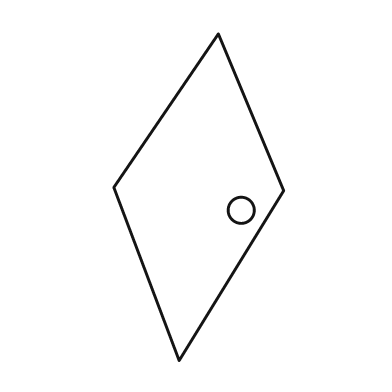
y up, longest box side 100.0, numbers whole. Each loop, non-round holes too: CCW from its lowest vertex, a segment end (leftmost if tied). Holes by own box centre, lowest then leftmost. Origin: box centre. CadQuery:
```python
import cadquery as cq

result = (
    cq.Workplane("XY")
    .moveTo(-6.0, -50.0)
    .lineTo(26.0, 2.0)
    .lineTo(6.0, 50.0)
    .lineTo(-26.0, 3.0)
    .close()
    .moveTo(13.0, -4.0)
    .circle(4.0)
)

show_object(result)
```